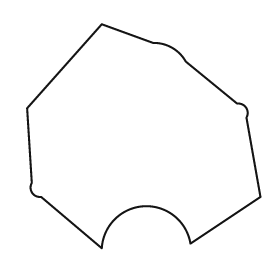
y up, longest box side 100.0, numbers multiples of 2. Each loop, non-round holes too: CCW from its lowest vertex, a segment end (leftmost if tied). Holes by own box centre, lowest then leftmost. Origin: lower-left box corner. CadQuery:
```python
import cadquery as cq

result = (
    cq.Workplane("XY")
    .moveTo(32.0, 0.0)
    .threePointArc((50.0, 18.0), (70.0, 2.0))
    .lineTo(100.0, 22.0)
    .lineTo(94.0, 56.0)
    .threePointArc((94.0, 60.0), (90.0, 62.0))
    .lineTo(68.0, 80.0)
    .threePointArc((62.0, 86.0), (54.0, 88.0))
    .lineTo(32.0, 96.0)
    .lineTo(0.0, 60.0)
    .lineTo(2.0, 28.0)
    .threePointArc((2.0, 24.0), (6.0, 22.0))
    .close()
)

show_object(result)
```